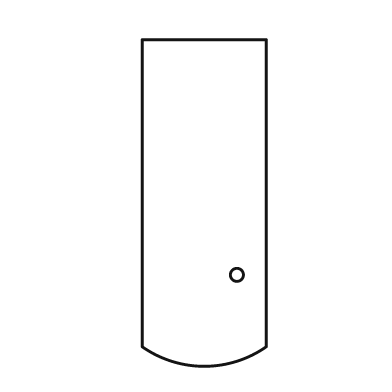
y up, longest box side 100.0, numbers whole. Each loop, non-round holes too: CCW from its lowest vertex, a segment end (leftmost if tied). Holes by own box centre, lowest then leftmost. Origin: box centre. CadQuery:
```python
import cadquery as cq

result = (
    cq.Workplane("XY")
    .moveTo(-19.0, -44.0)
    .threePointArc((0.0, -50.0), (19.0, -44.0))
    .lineTo(19.0, 50.0)
    .lineTo(-19.0, 50.0)
    .close()
    .moveTo(10.0, -22.0)
    .circle(2.0)
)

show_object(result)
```